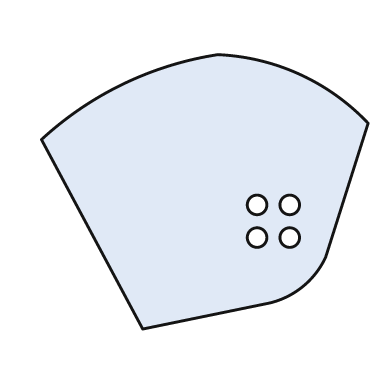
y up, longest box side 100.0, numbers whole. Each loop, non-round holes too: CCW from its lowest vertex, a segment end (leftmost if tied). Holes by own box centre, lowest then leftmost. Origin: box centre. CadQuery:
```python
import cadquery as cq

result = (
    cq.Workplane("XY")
    .moveTo(-19.0, -42.0)
    .lineTo(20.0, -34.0)
    .threePointArc((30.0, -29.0), (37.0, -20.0))
    .lineTo(50.0, 21.0)
    .threePointArc((29.0, 36.0), (4.0, 42.0))
    .threePointArc((-25.0, 33.0), (-50.0, 16.0))
    .close()
    .moveTo(16.0, -14.0)
    .circle(3.0)
    .moveTo(26.0, -14.0)
    .circle(3.0)
    .moveTo(16.0, -4.0)
    .circle(3.0)
    .moveTo(26.0, -4.0)
    .circle(3.0)
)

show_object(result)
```